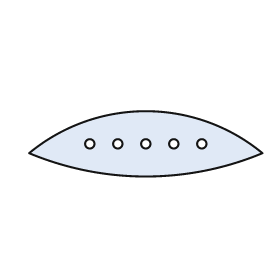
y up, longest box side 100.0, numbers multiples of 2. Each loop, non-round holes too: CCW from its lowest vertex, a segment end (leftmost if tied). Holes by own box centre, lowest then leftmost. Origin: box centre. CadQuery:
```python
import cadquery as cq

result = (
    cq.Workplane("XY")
    .moveTo(-50.0, -4.0)
    .threePointArc((0.0, -14.0), (50.0, -4.0))
    .threePointArc((0.0, 14.0), (-50.0, -4.0))
    .close()
    .moveTo(-24.0, 0.0)
    .circle(2.0)
    .moveTo(-12.0, 0.0)
    .circle(2.0)
    .moveTo(0.0, 0.0)
    .circle(2.0)
    .moveTo(12.0, 0.0)
    .circle(2.0)
    .moveTo(24.0, 0.0)
    .circle(2.0)
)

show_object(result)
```